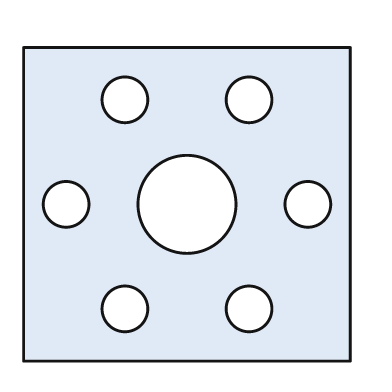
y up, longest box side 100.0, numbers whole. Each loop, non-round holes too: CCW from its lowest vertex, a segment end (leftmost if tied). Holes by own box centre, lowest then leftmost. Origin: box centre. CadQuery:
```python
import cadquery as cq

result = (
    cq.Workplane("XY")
    .moveTo(-50.0, -48.0)
    .lineTo(50.0, -48.0)
    .lineTo(50.0, 48.0)
    .lineTo(-50.0, 48.0)
    .close()
    .moveTo(-19.0, -32.0)
    .circle(7.0)
    .moveTo(19.0, -32.0)
    .circle(7.0)
    .moveTo(-37.0, 0.0)
    .circle(7.0)
    .moveTo(0.0, 0.0)
    .circle(15.0)
    .moveTo(37.0, 0.0)
    .circle(7.0)
    .moveTo(-19.0, 32.0)
    .circle(7.0)
    .moveTo(19.0, 32.0)
    .circle(7.0)
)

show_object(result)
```